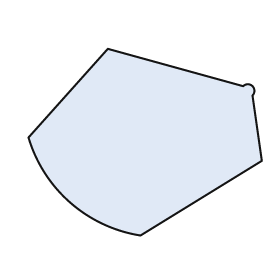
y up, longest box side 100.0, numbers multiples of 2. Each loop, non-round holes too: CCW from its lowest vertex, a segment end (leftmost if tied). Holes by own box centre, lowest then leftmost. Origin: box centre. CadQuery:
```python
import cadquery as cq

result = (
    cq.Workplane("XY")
    .moveTo(-2.0, -40.0)
    .lineTo(50.0, -8.0)
    .lineTo(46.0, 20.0)
    .threePointArc((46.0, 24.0), (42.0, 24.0))
    .lineTo(-16.0, 40.0)
    .lineTo(-50.0, 2.0)
    .threePointArc((-32.0, -26.0), (-2.0, -40.0))
    .close()
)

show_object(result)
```